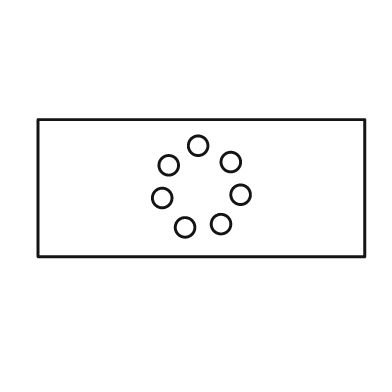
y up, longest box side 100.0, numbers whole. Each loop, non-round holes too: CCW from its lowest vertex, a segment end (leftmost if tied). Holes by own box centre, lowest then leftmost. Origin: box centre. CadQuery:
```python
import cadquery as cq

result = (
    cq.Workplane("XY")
    .moveTo(-50.0, -21.0)
    .lineTo(50.0, -21.0)
    .lineTo(50.0, 21.0)
    .lineTo(-50.0, 21.0)
    .close()
    .moveTo(-5.0, -12.0)
    .circle(3.0)
    .moveTo(6.0, -11.0)
    .circle(3.0)
    .moveTo(-12.0, -3.0)
    .circle(3.0)
    .moveTo(12.0, -2.0)
    .circle(3.0)
    .moveTo(-10.0, 7.0)
    .circle(3.0)
    .moveTo(9.0, 8.0)
    .circle(3.0)
    .moveTo(-1.0, 13.0)
    .circle(3.0)
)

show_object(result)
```